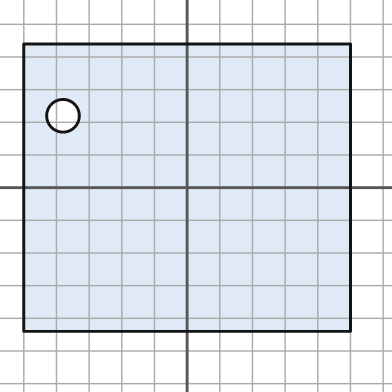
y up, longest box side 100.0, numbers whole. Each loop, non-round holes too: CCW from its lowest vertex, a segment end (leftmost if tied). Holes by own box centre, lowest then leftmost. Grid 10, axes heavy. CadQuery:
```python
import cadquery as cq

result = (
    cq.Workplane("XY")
    .moveTo(-50.0, -44.0)
    .lineTo(50.0, -44.0)
    .lineTo(50.0, 44.0)
    .lineTo(-50.0, 44.0)
    .close()
    .moveTo(-38.0, 22.0)
    .circle(5.0)
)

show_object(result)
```